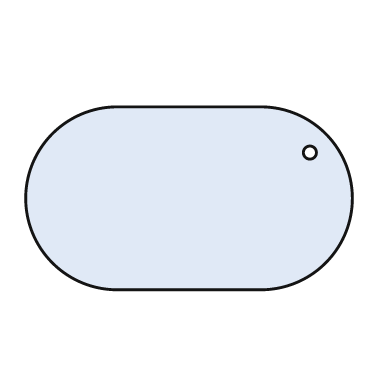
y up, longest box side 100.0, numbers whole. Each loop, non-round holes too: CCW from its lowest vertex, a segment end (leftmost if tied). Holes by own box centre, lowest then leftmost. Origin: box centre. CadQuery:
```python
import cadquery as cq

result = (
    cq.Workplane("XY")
    .moveTo(-22.0, -28.0)
    .lineTo(22.0, -28.0)
    .threePointArc((50.0, 0.0), (22.0, 28.0))
    .lineTo(-22.0, 28.0)
    .threePointArc((-50.0, 0.0), (-22.0, -28.0))
    .close()
    .moveTo(37.0, 14.0)
    .circle(2.0)
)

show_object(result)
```